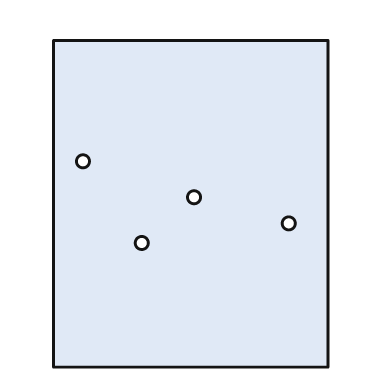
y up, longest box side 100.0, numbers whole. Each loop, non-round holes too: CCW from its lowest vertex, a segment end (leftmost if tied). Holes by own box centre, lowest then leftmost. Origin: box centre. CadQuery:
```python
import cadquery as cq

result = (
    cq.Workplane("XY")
    .moveTo(-42.0, -50.0)
    .lineTo(42.0, -50.0)
    .lineTo(42.0, 50.0)
    .lineTo(-42.0, 50.0)
    .close()
    .moveTo(-15.0, -12.0)
    .circle(2.0)
    .moveTo(30.0, -6.0)
    .circle(2.0)
    .moveTo(1.0, 2.0)
    .circle(2.0)
    .moveTo(-33.0, 13.0)
    .circle(2.0)
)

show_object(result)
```